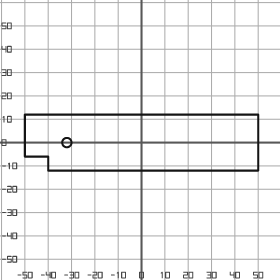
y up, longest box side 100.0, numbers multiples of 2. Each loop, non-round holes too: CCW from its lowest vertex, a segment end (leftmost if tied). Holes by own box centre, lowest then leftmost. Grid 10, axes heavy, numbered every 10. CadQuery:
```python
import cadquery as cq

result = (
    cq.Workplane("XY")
    .moveTo(-40.0, -12.0)
    .lineTo(50.0, -12.0)
    .lineTo(50.0, 12.0)
    .lineTo(-50.0, 12.0)
    .lineTo(-50.0, -6.0)
    .lineTo(-40.0, -6.0)
    .close()
    .moveTo(-32.0, 0.0)
    .circle(2.0)
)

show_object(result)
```